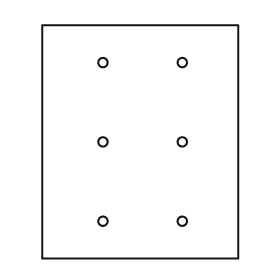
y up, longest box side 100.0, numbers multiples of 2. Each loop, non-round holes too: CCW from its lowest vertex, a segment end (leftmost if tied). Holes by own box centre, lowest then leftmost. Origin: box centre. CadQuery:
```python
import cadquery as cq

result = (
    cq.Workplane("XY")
    .moveTo(-42.0, -50.0)
    .lineTo(42.0, -50.0)
    .lineTo(42.0, 50.0)
    .lineTo(-42.0, 50.0)
    .close()
    .moveTo(-16.0, -34.0)
    .circle(2.0)
    .moveTo(18.0, -34.0)
    .circle(2.0)
    .moveTo(-16.0, 0.0)
    .circle(2.0)
    .moveTo(18.0, 0.0)
    .circle(2.0)
    .moveTo(-16.0, 34.0)
    .circle(2.0)
    .moveTo(18.0, 34.0)
    .circle(2.0)
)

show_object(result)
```